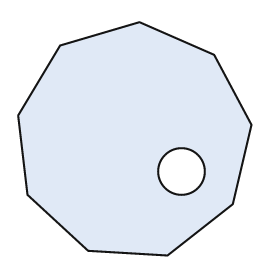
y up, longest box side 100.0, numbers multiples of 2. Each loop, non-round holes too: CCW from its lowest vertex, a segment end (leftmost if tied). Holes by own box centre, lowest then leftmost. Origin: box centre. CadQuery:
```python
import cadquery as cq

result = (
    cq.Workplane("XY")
    .moveTo(14.0, -50.0)
    .lineTo(42.0, -28.0)
    .lineTo(50.0, 6.0)
    .lineTo(34.0, 36.0)
    .lineTo(2.0, 50.0)
    .lineTo(-32.0, 40.0)
    .lineTo(-50.0, 10.0)
    .lineTo(-46.0, -24.0)
    .lineTo(-20.0, -48.0)
    .close()
    .moveTo(20.0, -14.0)
    .circle(10.0)
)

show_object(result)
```